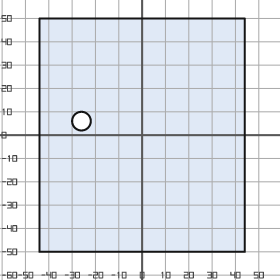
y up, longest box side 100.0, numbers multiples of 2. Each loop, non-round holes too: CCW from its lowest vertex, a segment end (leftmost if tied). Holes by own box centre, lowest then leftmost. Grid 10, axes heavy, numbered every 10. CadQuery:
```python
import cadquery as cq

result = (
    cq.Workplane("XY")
    .moveTo(-44.0, -50.0)
    .lineTo(44.0, -50.0)
    .lineTo(44.0, 50.0)
    .lineTo(-44.0, 50.0)
    .close()
    .moveTo(-26.0, 6.0)
    .circle(4.0)
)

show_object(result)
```